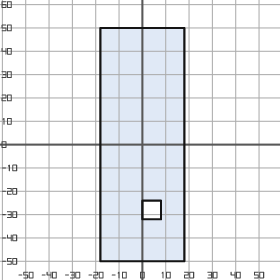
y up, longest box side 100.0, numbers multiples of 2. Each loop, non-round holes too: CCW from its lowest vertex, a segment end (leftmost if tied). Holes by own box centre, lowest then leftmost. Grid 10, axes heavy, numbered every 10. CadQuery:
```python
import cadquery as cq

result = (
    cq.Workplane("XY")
    .moveTo(-18.0, -50.0)
    .lineTo(18.0, -50.0)
    .lineTo(18.0, 50.0)
    .lineTo(-18.0, 50.0)
    .close()
    .moveTo(0.0, -32.0)
    .lineTo(8.0, -32.0)
    .lineTo(8.0, -24.0)
    .lineTo(0.0, -24.0)
    .close()
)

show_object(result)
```